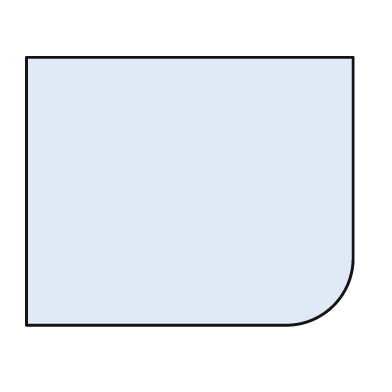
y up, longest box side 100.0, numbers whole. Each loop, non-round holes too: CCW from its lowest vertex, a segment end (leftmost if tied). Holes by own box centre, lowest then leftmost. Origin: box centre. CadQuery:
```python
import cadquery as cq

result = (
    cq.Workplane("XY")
    .moveTo(-50.0, -41.0)
    .lineTo(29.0, -41.0)
    .threePointArc((44.0, -35.0), (50.0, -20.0))
    .lineTo(50.0, 41.0)
    .lineTo(-50.0, 41.0)
    .close()
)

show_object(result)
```